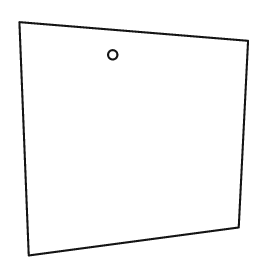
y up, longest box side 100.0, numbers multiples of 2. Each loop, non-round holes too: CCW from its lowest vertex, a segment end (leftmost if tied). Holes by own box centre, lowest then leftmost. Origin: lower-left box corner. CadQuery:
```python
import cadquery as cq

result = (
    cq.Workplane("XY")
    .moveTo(4.0, 0.0)
    .lineTo(94.0, 12.0)
    .lineTo(98.0, 92.0)
    .lineTo(0.0, 100.0)
    .close()
    .moveTo(40.0, 86.0)
    .circle(2.0)
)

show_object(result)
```